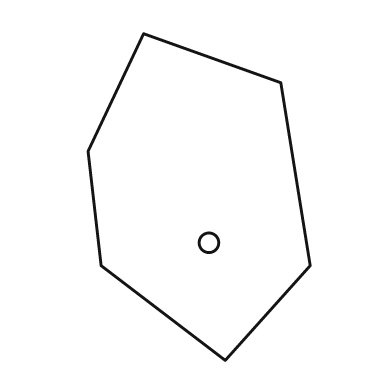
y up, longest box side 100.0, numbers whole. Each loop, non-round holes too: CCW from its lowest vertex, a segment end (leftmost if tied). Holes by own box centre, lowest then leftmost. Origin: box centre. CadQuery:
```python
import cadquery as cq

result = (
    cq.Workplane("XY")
    .moveTo(8.0, -50.0)
    .lineTo(34.0, -21.0)
    .lineTo(25.0, 35.0)
    .lineTo(-17.0, 50.0)
    .lineTo(-34.0, 14.0)
    .lineTo(-30.0, -21.0)
    .close()
    .moveTo(3.0, -14.0)
    .circle(3.0)
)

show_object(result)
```